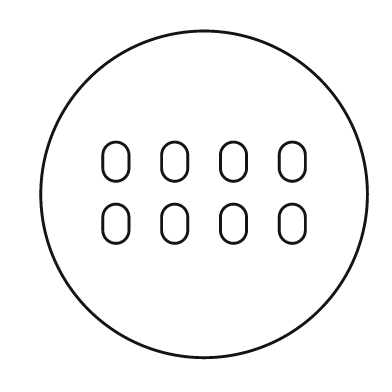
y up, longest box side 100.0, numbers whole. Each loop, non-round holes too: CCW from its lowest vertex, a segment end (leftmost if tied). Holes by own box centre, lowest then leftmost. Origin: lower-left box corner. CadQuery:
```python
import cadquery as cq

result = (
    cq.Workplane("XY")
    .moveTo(50.0, 50.0)
    .circle(50.0)
    .moveTo(19.0, 39.0)
    .threePointArc((23.0, 35.0), (27.0, 39.0))
    .lineTo(27.0, 43.0)
    .threePointArc((23.0, 47.0), (19.0, 43.0))
    .close()
    .moveTo(37.0, 39.0)
    .threePointArc((41.0, 35.0), (45.0, 39.0))
    .lineTo(45.0, 43.0)
    .threePointArc((41.0, 47.0), (37.0, 43.0))
    .close()
    .moveTo(55.0, 39.0)
    .threePointArc((59.0, 35.0), (63.0, 39.0))
    .lineTo(63.0, 43.0)
    .threePointArc((59.0, 47.0), (55.0, 43.0))
    .close()
    .moveTo(73.0, 39.0)
    .threePointArc((77.0, 35.0), (81.0, 39.0))
    .lineTo(81.0, 43.0)
    .threePointArc((77.0, 47.0), (73.0, 43.0))
    .close()
    .moveTo(19.0, 58.0)
    .threePointArc((23.0, 54.0), (27.0, 58.0))
    .lineTo(27.0, 62.0)
    .threePointArc((23.0, 66.0), (19.0, 62.0))
    .close()
    .moveTo(37.0, 58.0)
    .threePointArc((41.0, 54.0), (45.0, 58.0))
    .lineTo(45.0, 62.0)
    .threePointArc((41.0, 66.0), (37.0, 62.0))
    .close()
    .moveTo(55.0, 58.0)
    .threePointArc((59.0, 54.0), (63.0, 58.0))
    .lineTo(63.0, 62.0)
    .threePointArc((59.0, 66.0), (55.0, 62.0))
    .close()
    .moveTo(73.0, 58.0)
    .threePointArc((77.0, 54.0), (81.0, 58.0))
    .lineTo(81.0, 62.0)
    .threePointArc((77.0, 66.0), (73.0, 62.0))
    .close()
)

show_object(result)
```